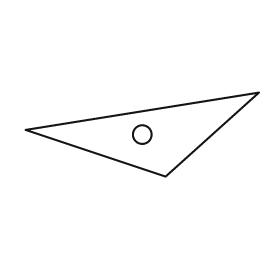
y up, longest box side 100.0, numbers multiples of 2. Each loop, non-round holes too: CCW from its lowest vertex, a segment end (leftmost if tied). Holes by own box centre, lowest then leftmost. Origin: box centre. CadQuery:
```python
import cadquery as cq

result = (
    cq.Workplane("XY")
    .moveTo(10.0, -18.0)
    .lineTo(50.0, 18.0)
    .lineTo(-50.0, 2.0)
    .close()
    .moveTo(0.0, 0.0)
    .circle(4.0)
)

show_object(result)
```